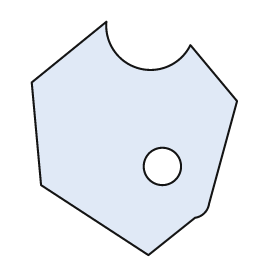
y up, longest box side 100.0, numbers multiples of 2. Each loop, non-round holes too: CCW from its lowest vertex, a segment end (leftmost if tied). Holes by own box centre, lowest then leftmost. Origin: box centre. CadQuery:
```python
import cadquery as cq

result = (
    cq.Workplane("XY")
    .moveTo(6.0, -50.0)
    .lineTo(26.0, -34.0)
    .threePointArc((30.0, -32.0), (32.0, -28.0))
    .lineTo(44.0, 16.0)
    .lineTo(24.0, 40.0)
    .threePointArc((2.0, 30.0), (-12.0, 50.0))
    .lineTo(-44.0, 24.0)
    .lineTo(-40.0, -20.0)
    .close()
    .moveTo(12.0, -12.0)
    .circle(8.0)
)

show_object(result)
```